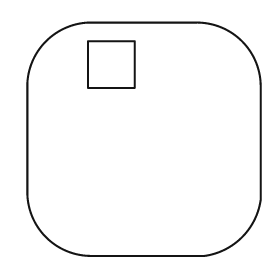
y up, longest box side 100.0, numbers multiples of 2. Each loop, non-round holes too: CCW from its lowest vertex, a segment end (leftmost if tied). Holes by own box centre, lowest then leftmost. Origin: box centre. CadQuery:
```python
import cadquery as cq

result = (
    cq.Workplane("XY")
    .moveTo(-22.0, -50.0)
    .lineTo(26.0, -50.0)
    .threePointArc((42.0, -42.0), (50.0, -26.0))
    .lineTo(50.0, 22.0)
    .threePointArc((42.0, 42.0), (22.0, 50.0))
    .lineTo(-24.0, 50.0)
    .threePointArc((-42.0, 42.0), (-50.0, 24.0))
    .lineTo(-50.0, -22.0)
    .threePointArc((-42.0, -42.0), (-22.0, -50.0))
    .close()
    .moveTo(-24.0, 22.0)
    .lineTo(-4.0, 22.0)
    .lineTo(-4.0, 42.0)
    .lineTo(-24.0, 42.0)
    .close()
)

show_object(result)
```